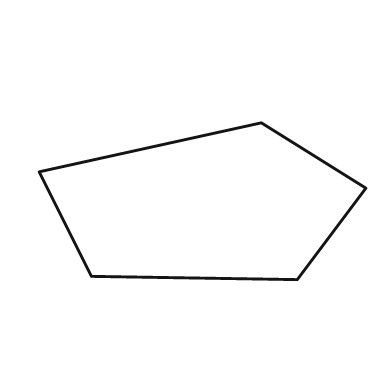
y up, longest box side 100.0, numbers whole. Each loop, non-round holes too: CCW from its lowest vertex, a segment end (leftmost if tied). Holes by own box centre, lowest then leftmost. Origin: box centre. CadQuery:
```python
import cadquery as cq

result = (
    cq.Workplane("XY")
    .moveTo(29.0, -24.0)
    .lineTo(50.0, 4.0)
    .lineTo(18.0, 24.0)
    .lineTo(-50.0, 9.0)
    .lineTo(-34.0, -23.0)
    .close()
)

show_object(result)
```